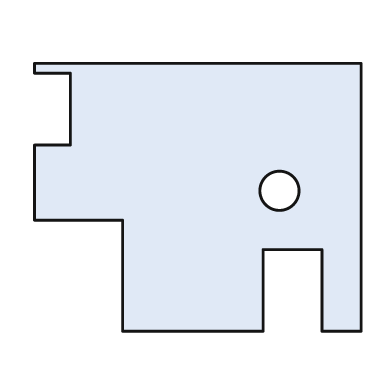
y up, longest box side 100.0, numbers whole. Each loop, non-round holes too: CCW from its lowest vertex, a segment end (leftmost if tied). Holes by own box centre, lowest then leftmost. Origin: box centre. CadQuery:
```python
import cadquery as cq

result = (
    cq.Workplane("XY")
    .moveTo(-23.0, -41.0)
    .lineTo(20.0, -41.0)
    .lineTo(20.0, -16.0)
    .lineTo(38.0, -16.0)
    .lineTo(38.0, -41.0)
    .lineTo(50.0, -41.0)
    .lineTo(50.0, 41.0)
    .lineTo(-50.0, 41.0)
    .lineTo(-50.0, 38.0)
    .lineTo(-39.0, 38.0)
    .lineTo(-39.0, 16.0)
    .lineTo(-50.0, 16.0)
    .lineTo(-50.0, -7.0)
    .lineTo(-23.0, -7.0)
    .close()
    .moveTo(25.0, 2.0)
    .circle(6.0)
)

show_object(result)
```